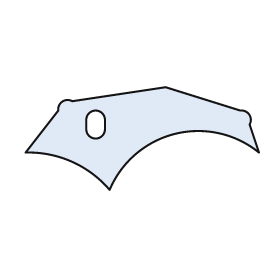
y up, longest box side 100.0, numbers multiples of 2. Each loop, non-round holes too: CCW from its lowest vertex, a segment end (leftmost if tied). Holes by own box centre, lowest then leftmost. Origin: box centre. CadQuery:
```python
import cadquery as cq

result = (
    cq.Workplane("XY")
    .moveTo(-14.0, -22.0)
    .threePointArc((14.0, 2.0), (50.0, -6.0))
    .lineTo(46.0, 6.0)
    .threePointArc((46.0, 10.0), (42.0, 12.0))
    .lineTo(10.0, 22.0)
    .lineTo(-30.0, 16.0)
    .threePointArc((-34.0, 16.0), (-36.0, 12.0))
    .lineTo(-50.0, -6.0)
    .threePointArc((-30.0, -10.0), (-14.0, -22.0))
    .close()
    .moveTo(-24.0, 4.0)
    .threePointArc((-20.0, 0.0), (-16.0, 4.0))
    .lineTo(-16.0, 8.0)
    .threePointArc((-20.0, 12.0), (-24.0, 8.0))
    .close()
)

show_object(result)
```